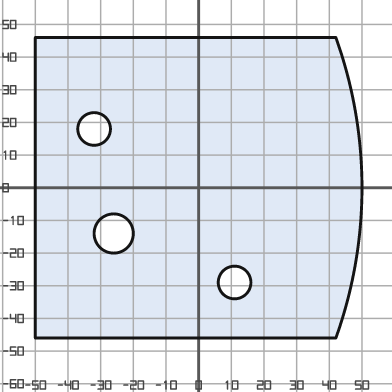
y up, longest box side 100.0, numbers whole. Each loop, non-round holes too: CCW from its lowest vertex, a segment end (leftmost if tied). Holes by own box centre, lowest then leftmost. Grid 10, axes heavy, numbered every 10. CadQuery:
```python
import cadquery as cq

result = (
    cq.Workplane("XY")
    .moveTo(-50.0, -46.0)
    .lineTo(42.0, -46.0)
    .threePointArc((50.0, 0.0), (42.0, 46.0))
    .lineTo(-50.0, 46.0)
    .close()
    .moveTo(11.0, -29.0)
    .circle(5.0)
    .moveTo(-26.0, -14.0)
    .circle(6.0)
    .moveTo(-32.0, 18.0)
    .circle(5.0)
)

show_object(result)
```